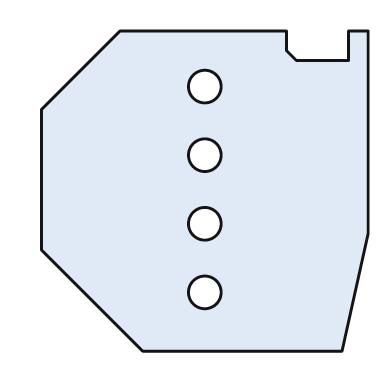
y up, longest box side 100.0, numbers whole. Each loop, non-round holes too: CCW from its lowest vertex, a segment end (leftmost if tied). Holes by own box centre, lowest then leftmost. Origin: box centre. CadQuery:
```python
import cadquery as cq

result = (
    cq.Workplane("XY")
    .moveTo(-19.0, -49.0)
    .lineTo(42.0, -49.0)
    .lineTo(50.0, -13.0)
    .lineTo(50.0, 49.0)
    .lineTo(44.0, 49.0)
    .lineTo(44.0, 40.0)
    .lineTo(28.0, 40.0)
    .lineTo(25.0, 43.0)
    .lineTo(25.0, 49.0)
    .lineTo(-26.0, 49.0)
    .lineTo(-50.0, 25.0)
    .lineTo(-50.0, -18.0)
    .close()
    .moveTo(0.0, -31.0)
    .circle(5.0)
    .moveTo(0.0, -10.0)
    .circle(5.0)
    .moveTo(0.0, 11.0)
    .circle(5.0)
    .moveTo(0.0, 32.0)
    .circle(5.0)
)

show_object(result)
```